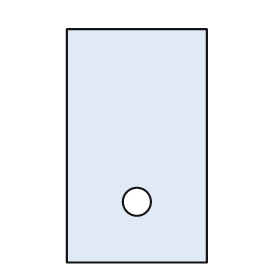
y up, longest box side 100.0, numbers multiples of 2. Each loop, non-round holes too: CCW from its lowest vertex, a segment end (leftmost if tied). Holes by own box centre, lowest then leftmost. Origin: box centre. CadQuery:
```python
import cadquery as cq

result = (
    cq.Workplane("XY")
    .moveTo(-30.0, -50.0)
    .lineTo(30.0, -50.0)
    .lineTo(30.0, 50.0)
    .lineTo(-30.0, 50.0)
    .close()
    .moveTo(0.0, -24.0)
    .circle(6.0)
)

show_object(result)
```